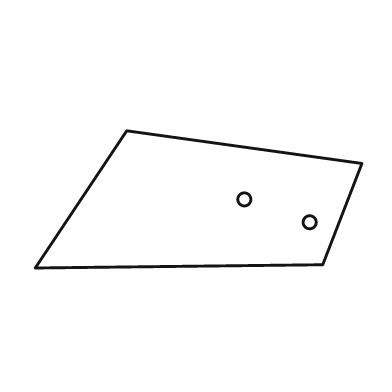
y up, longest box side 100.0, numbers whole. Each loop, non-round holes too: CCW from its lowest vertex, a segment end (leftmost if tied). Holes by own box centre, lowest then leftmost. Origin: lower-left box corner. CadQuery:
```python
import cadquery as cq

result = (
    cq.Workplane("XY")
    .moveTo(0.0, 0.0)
    .lineTo(88.0, 1.0)
    .lineTo(100.0, 32.0)
    .lineTo(28.0, 42.0)
    .close()
    .moveTo(84.0, 14.0)
    .circle(2.0)
    .moveTo(64.0, 21.0)
    .circle(2.0)
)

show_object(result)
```